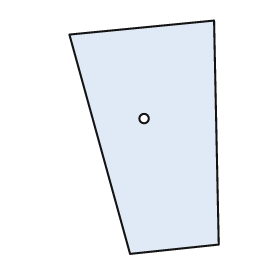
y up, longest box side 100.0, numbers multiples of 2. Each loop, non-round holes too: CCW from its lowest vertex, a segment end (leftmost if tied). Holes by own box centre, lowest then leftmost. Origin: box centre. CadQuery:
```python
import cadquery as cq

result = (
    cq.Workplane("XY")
    .moveTo(-6.0, -50.0)
    .lineTo(32.0, -46.0)
    .lineTo(30.0, 50.0)
    .lineTo(-32.0, 44.0)
    .close()
    .moveTo(0.0, 8.0)
    .circle(2.0)
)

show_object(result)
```